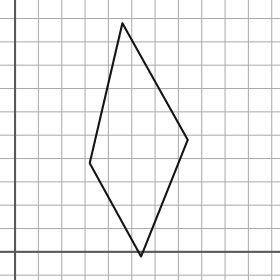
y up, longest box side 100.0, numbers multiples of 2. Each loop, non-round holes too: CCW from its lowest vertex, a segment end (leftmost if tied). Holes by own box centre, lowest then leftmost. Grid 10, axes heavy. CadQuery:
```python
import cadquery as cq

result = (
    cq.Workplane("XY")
    .moveTo(54.0, -2.0)
    .lineTo(74.0, 48.0)
    .lineTo(46.0, 98.0)
    .lineTo(32.0, 38.0)
    .close()
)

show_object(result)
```